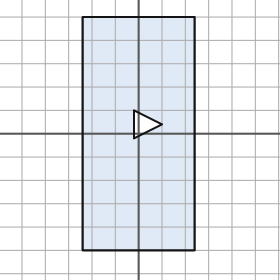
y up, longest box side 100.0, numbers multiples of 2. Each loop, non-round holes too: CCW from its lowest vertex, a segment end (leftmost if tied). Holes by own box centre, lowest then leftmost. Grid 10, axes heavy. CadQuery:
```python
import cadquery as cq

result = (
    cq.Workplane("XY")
    .moveTo(-24.0, -50.0)
    .lineTo(24.0, -50.0)
    .lineTo(24.0, 50.0)
    .lineTo(-24.0, 50.0)
    .close()
    .moveTo(-2.0, -2.0)
    .lineTo(10.0, 4.0)
    .lineTo(-2.0, 10.0)
    .close()
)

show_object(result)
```